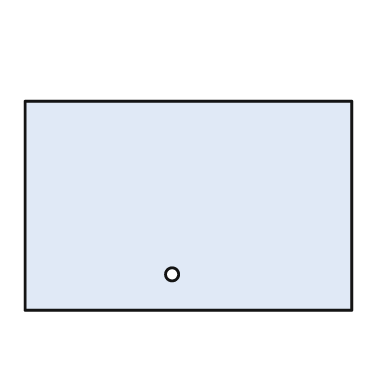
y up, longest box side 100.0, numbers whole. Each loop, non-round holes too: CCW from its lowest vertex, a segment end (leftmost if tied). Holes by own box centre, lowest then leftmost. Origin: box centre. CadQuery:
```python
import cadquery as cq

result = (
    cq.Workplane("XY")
    .moveTo(-50.0, -32.0)
    .lineTo(50.0, -32.0)
    .lineTo(50.0, 32.0)
    .lineTo(-50.0, 32.0)
    .close()
    .moveTo(-5.0, -21.0)
    .circle(2.0)
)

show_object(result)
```